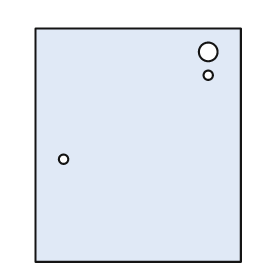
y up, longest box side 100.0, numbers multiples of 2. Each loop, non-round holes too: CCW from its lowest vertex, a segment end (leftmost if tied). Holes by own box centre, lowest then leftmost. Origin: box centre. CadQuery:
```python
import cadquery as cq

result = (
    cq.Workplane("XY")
    .moveTo(-44.0, -50.0)
    .lineTo(44.0, -50.0)
    .lineTo(44.0, 50.0)
    .lineTo(-44.0, 50.0)
    .close()
    .moveTo(-32.0, -6.0)
    .circle(2.0)
    .moveTo(30.0, 30.0)
    .circle(2.0)
    .moveTo(30.0, 40.0)
    .circle(4.0)
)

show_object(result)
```